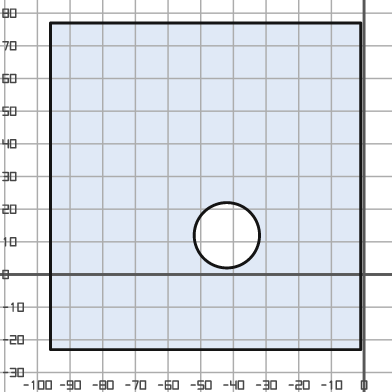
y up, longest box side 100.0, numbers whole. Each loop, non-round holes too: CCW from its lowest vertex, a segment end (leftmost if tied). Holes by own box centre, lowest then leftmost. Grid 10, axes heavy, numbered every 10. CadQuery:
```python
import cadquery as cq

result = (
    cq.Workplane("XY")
    .moveTo(-96.0, -23.0)
    .lineTo(-1.0, -23.0)
    .lineTo(-1.0, 77.0)
    .lineTo(-96.0, 77.0)
    .close()
    .moveTo(-42.0, 12.0)
    .circle(10.0)
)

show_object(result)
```